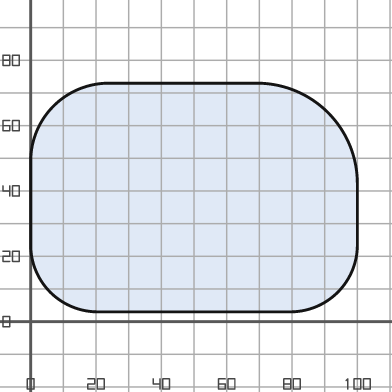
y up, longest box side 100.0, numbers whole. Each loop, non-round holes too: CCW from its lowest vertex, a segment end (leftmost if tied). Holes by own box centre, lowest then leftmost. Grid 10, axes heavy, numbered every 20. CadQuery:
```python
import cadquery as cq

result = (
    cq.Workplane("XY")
    .moveTo(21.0, 3.0)
    .lineTo(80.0, 3.0)
    .threePointArc((94.0, 9.0), (100.0, 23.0))
    .lineTo(100.0, 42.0)
    .threePointArc((91.0, 64.0), (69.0, 73.0))
    .lineTo(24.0, 73.0)
    .threePointArc((7.0, 66.0), (0.0, 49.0))
    .lineTo(0.0, 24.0)
    .threePointArc((6.0, 9.0), (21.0, 3.0))
    .close()
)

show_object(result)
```